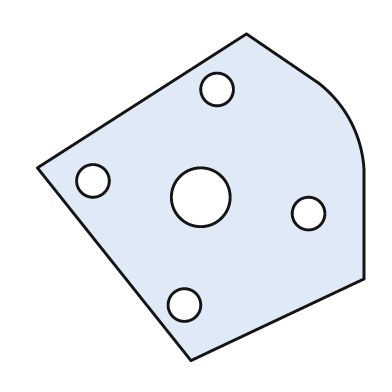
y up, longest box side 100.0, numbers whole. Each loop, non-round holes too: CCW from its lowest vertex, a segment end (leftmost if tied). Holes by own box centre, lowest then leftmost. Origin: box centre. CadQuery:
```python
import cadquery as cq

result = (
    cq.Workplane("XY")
    .moveTo(-3.0, -50.0)
    .lineTo(50.0, -25.0)
    .lineTo(50.0, 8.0)
    .threePointArc((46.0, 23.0), (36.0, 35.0))
    .lineTo(14.0, 50.0)
    .lineTo(-50.0, 9.0)
    .close()
    .moveTo(-5.0, -33.0)
    .circle(5.0)
    .moveTo(33.0, -5.0)
    .circle(5.0)
    .moveTo(0.0, 0.0)
    .circle(9.0)
    .moveTo(-33.0, 5.0)
    .circle(5.0)
    .moveTo(5.0, 33.0)
    .circle(5.0)
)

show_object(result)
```